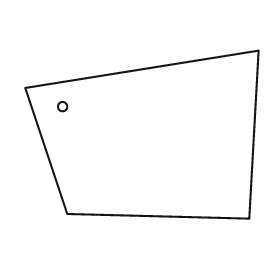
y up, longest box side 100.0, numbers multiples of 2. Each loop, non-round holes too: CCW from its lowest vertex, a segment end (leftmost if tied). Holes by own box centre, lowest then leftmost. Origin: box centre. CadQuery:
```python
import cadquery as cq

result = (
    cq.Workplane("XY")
    .moveTo(46.0, -36.0)
    .lineTo(50.0, 36.0)
    .lineTo(-50.0, 20.0)
    .lineTo(-32.0, -34.0)
    .close()
    .moveTo(-34.0, 12.0)
    .circle(2.0)
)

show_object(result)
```